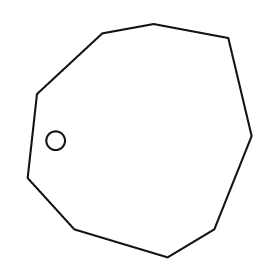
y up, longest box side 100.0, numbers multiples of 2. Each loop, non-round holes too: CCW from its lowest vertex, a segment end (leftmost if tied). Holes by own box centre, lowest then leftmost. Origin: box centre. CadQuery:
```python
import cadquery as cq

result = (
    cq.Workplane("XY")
    .moveTo(12.0, -50.0)
    .lineTo(32.0, -38.0)
    .lineTo(48.0, 2.0)
    .lineTo(38.0, 44.0)
    .lineTo(6.0, 50.0)
    .lineTo(-16.0, 46.0)
    .lineTo(-44.0, 20.0)
    .lineTo(-48.0, -16.0)
    .lineTo(-28.0, -38.0)
    .close()
    .moveTo(-36.0, 0.0)
    .circle(4.0)
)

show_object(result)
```